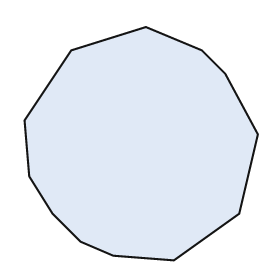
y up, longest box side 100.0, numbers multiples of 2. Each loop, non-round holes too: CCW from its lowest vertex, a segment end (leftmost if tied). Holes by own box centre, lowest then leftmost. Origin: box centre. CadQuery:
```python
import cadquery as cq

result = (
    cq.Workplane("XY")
    .moveTo(14.0, -50.0)
    .lineTo(42.0, -30.0)
    .lineTo(50.0, 4.0)
    .lineTo(36.0, 30.0)
    .lineTo(26.0, 40.0)
    .lineTo(2.0, 50.0)
    .lineTo(-30.0, 40.0)
    .lineTo(-50.0, 10.0)
    .lineTo(-48.0, -14.0)
    .lineTo(-38.0, -30.0)
    .lineTo(-26.0, -42.0)
    .lineTo(-12.0, -48.0)
    .close()
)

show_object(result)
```